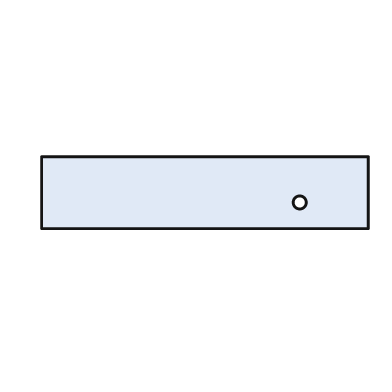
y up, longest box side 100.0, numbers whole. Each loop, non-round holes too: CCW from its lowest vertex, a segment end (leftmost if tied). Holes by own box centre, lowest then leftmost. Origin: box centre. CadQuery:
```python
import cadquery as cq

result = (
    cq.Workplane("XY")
    .moveTo(-50.0, -11.0)
    .lineTo(50.0, -11.0)
    .lineTo(50.0, 11.0)
    .lineTo(-50.0, 11.0)
    .close()
    .moveTo(29.0, -3.0)
    .circle(2.0)
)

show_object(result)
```